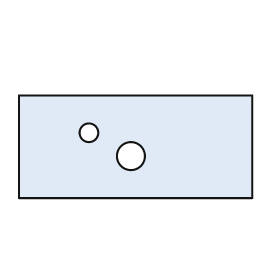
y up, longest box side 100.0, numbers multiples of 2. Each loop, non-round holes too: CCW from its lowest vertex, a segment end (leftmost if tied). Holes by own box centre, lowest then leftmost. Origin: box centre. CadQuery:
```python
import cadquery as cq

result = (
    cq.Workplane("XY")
    .moveTo(-50.0, -22.0)
    .lineTo(50.0, -22.0)
    .lineTo(50.0, 22.0)
    .lineTo(-50.0, 22.0)
    .close()
    .moveTo(-2.0, -4.0)
    .circle(6.0)
    .moveTo(-20.0, 6.0)
    .circle(4.0)
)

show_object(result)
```